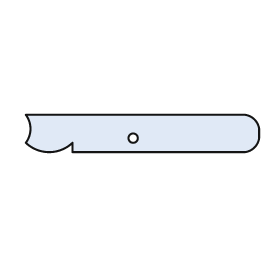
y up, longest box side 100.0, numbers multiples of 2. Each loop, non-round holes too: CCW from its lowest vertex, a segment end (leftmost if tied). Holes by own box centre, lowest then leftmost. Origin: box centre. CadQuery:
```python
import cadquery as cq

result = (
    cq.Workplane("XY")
    .moveTo(-30.0, -8.0)
    .lineTo(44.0, -8.0)
    .threePointArc((48.0, -6.0), (50.0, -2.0))
    .lineTo(50.0, 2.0)
    .threePointArc((48.0, 6.0), (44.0, 8.0))
    .lineTo(-50.0, 8.0)
    .threePointArc((-48.0, 2.0), (-50.0, -4.0))
    .threePointArc((-40.0, -8.0), (-30.0, -4.0))
    .close()
    .moveTo(-4.0, -2.0)
    .circle(2.0)
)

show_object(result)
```